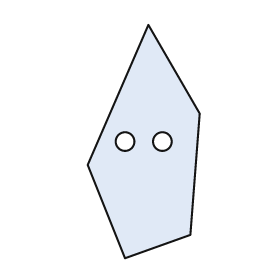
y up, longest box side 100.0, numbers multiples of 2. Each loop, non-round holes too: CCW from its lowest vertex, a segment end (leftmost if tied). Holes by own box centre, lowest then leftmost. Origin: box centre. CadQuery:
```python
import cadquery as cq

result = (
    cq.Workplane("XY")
    .moveTo(-8.0, -50.0)
    .lineTo(20.0, -40.0)
    .lineTo(24.0, 12.0)
    .lineTo(2.0, 50.0)
    .lineTo(-24.0, -10.0)
    .close()
    .moveTo(-8.0, 0.0)
    .circle(4.0)
    .moveTo(8.0, 0.0)
    .circle(4.0)
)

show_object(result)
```